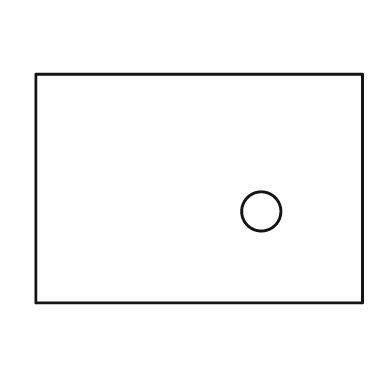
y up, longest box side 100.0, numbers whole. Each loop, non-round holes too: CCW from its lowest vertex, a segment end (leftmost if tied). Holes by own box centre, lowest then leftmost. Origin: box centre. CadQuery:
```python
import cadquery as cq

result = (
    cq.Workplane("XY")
    .moveTo(-50.0, -35.0)
    .lineTo(50.0, -35.0)
    .lineTo(50.0, 35.0)
    .lineTo(-50.0, 35.0)
    .close()
    .moveTo(19.0, -7.0)
    .circle(6.0)
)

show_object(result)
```